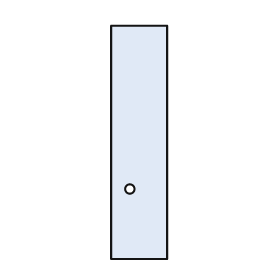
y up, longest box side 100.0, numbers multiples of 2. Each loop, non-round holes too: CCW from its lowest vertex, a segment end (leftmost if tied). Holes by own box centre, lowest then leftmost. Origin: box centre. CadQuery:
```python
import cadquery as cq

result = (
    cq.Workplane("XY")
    .moveTo(-12.0, -50.0)
    .lineTo(12.0, -50.0)
    .lineTo(12.0, 50.0)
    .lineTo(-12.0, 50.0)
    .close()
    .moveTo(-4.0, -20.0)
    .circle(2.0)
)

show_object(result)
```